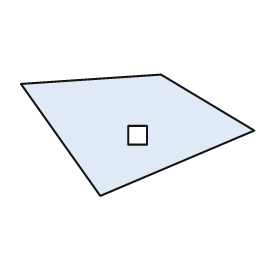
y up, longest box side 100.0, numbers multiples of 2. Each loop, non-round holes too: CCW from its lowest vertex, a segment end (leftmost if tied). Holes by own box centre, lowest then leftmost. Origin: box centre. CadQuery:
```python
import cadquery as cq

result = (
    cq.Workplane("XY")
    .moveTo(-16.0, -26.0)
    .lineTo(50.0, 2.0)
    .lineTo(10.0, 26.0)
    .lineTo(-50.0, 22.0)
    .close()
    .moveTo(-4.0, -4.0)
    .lineTo(4.0, -4.0)
    .lineTo(4.0, 4.0)
    .lineTo(-4.0, 4.0)
    .close()
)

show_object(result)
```